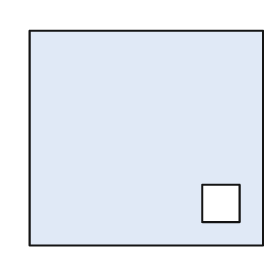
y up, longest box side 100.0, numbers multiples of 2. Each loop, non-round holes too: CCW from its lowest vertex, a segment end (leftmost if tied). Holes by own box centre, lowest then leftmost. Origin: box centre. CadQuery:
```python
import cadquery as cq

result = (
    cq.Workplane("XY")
    .moveTo(-50.0, -46.0)
    .lineTo(50.0, -46.0)
    .lineTo(50.0, 46.0)
    .lineTo(-50.0, 46.0)
    .close()
    .moveTo(24.0, -36.0)
    .lineTo(40.0, -36.0)
    .lineTo(40.0, -20.0)
    .lineTo(24.0, -20.0)
    .close()
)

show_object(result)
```